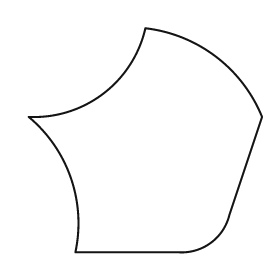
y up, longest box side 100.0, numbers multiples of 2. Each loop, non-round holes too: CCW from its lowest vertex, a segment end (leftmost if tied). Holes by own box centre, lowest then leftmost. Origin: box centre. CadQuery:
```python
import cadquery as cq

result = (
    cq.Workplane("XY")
    .moveTo(-30.0, -48.0)
    .lineTo(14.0, -48.0)
    .threePointArc((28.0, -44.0), (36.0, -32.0))
    .lineTo(50.0, 10.0)
    .threePointArc((30.0, 36.0), (0.0, 48.0))
    .threePointArc((-18.0, 20.0), (-50.0, 10.0))
    .threePointArc((-32.0, -16.0), (-30.0, -48.0))
    .close()
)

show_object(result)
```